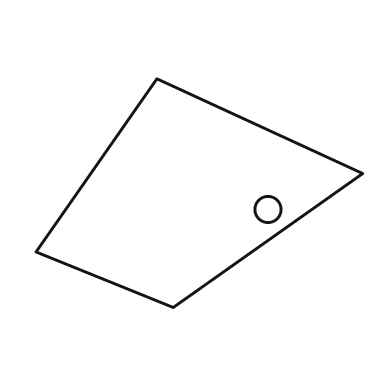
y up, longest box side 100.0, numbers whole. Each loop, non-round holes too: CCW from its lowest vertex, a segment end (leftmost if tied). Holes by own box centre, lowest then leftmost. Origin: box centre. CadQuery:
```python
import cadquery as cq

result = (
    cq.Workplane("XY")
    .moveTo(-8.0, -35.0)
    .lineTo(50.0, 6.0)
    .lineTo(-13.0, 35.0)
    .lineTo(-50.0, -18.0)
    .close()
    .moveTo(21.0, -5.0)
    .circle(4.0)
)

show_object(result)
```